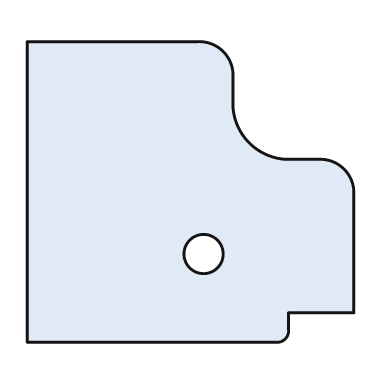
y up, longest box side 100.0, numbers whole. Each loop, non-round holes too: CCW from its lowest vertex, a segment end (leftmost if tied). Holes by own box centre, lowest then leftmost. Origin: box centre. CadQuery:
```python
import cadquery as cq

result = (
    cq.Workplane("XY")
    .moveTo(-50.0, -46.0)
    .lineTo(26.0, -46.0)
    .threePointArc((29.0, -45.0), (30.0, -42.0))
    .lineTo(30.0, -37.0)
    .lineTo(50.0, -37.0)
    .lineTo(50.0, 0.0)
    .threePointArc((47.0, 7.0), (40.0, 10.0))
    .lineTo(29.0, 10.0)
    .threePointArc((18.0, 15.0), (13.0, 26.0))
    .lineTo(13.0, 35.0)
    .threePointArc((10.0, 43.0), (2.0, 46.0))
    .lineTo(-50.0, 46.0)
    .close()
    .moveTo(4.0, -19.0)
    .circle(6.0)
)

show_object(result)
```